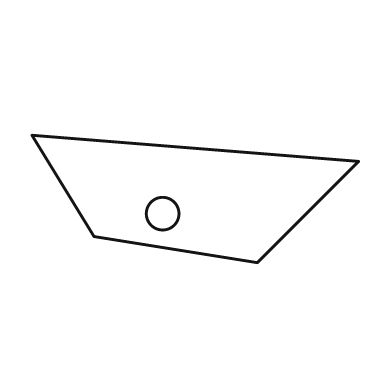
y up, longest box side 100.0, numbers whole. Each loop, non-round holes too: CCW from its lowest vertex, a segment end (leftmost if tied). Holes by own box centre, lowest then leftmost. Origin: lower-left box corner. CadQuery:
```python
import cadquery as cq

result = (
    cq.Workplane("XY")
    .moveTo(69.0, 0.0)
    .lineTo(100.0, 31.0)
    .lineTo(0.0, 39.0)
    .lineTo(19.0, 8.0)
    .close()
    .moveTo(40.0, 15.0)
    .circle(5.0)
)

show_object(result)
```